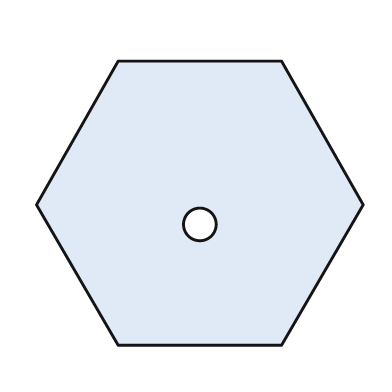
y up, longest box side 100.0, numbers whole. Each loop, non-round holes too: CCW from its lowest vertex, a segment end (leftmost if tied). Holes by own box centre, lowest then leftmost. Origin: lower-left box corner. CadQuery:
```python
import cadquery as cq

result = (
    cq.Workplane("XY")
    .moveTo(25.0, 0.0)
    .lineTo(75.0, 0.0)
    .lineTo(100.0, 43.0)
    .lineTo(75.0, 87.0)
    .lineTo(25.0, 87.0)
    .lineTo(0.0, 43.0)
    .close()
    .moveTo(50.0, 37.0)
    .circle(5.0)
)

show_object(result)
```